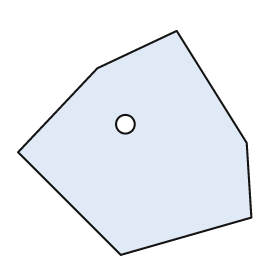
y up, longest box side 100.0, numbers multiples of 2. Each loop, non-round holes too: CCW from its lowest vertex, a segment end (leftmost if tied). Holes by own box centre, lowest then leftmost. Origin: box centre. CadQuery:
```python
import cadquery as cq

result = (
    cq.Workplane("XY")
    .moveTo(-6.0, -48.0)
    .lineTo(50.0, -32.0)
    .lineTo(48.0, 0.0)
    .lineTo(18.0, 48.0)
    .lineTo(-16.0, 32.0)
    .lineTo(-50.0, -4.0)
    .close()
    .moveTo(-4.0, 8.0)
    .circle(4.0)
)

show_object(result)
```